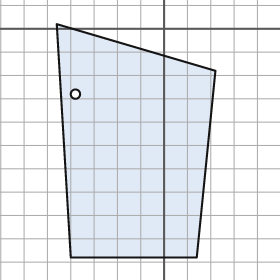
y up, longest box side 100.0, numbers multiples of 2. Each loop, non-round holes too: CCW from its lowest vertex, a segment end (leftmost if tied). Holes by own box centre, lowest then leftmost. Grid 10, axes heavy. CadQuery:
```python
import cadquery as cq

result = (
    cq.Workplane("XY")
    .moveTo(-40.0, -98.0)
    .lineTo(14.0, -98.0)
    .lineTo(22.0, -18.0)
    .lineTo(-46.0, 2.0)
    .close()
    .moveTo(-38.0, -28.0)
    .circle(2.0)
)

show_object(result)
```